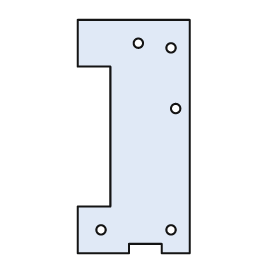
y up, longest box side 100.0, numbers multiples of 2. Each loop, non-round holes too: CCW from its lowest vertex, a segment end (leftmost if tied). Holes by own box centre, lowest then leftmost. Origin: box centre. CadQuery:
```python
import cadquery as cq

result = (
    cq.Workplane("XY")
    .moveTo(-24.0, -50.0)
    .lineTo(-2.0, -50.0)
    .lineTo(-2.0, -46.0)
    .lineTo(12.0, -46.0)
    .lineTo(12.0, -50.0)
    .lineTo(24.0, -50.0)
    .lineTo(24.0, 50.0)
    .lineTo(-24.0, 50.0)
    .lineTo(-24.0, 30.0)
    .lineTo(-10.0, 30.0)
    .lineTo(-10.0, -30.0)
    .lineTo(-24.0, -30.0)
    .close()
    .moveTo(-14.0, -40.0)
    .circle(2.0)
    .moveTo(16.0, -40.0)
    .circle(2.0)
    .moveTo(18.0, 12.0)
    .circle(2.0)
    .moveTo(16.0, 38.0)
    .circle(2.0)
    .moveTo(2.0, 40.0)
    .circle(2.0)
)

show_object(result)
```